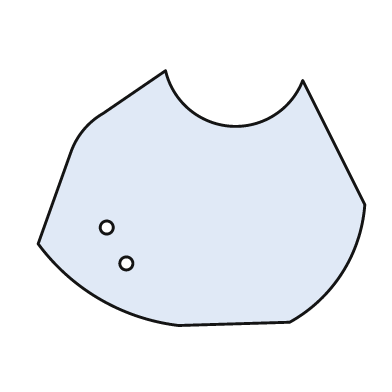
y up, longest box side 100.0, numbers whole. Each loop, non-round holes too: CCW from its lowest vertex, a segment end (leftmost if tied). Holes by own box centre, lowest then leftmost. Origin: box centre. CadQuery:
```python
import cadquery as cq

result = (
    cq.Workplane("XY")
    .moveTo(-7.0, -39.0)
    .lineTo(27.0, -38.0)
    .threePointArc((43.0, -23.0), (50.0, -2.0))
    .lineTo(31.0, 36.0)
    .threePointArc((9.0, 22.0), (-11.0, 39.0))
    .lineTo(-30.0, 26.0)
    .threePointArc((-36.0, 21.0), (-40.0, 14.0))
    .lineTo(-50.0, -14.0)
    .threePointArc((-31.0, -31.0), (-7.0, -39.0))
    .close()
    .moveTo(-23.0, -20.0)
    .circle(2.0)
    .moveTo(-29.0, -9.0)
    .circle(2.0)
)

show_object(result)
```